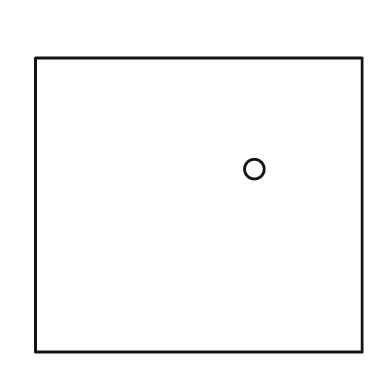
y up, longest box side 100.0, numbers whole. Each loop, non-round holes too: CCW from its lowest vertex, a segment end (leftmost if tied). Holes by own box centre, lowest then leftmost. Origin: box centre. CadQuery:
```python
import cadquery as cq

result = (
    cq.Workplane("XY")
    .moveTo(-50.0, -45.0)
    .lineTo(50.0, -45.0)
    .lineTo(50.0, 45.0)
    .lineTo(-50.0, 45.0)
    .close()
    .moveTo(17.0, 11.0)
    .circle(3.0)
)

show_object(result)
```